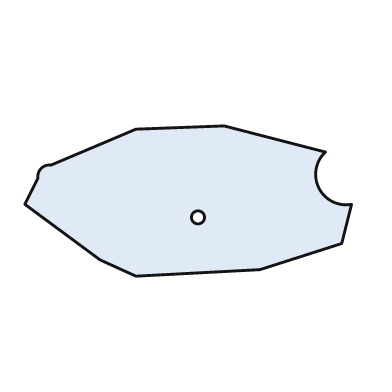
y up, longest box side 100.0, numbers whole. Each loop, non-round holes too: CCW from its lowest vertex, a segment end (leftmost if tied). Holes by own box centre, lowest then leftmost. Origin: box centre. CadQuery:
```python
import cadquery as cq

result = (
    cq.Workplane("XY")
    .moveTo(-16.0, -23.0)
    .lineTo(22.0, -21.0)
    .lineTo(47.0, -13.0)
    .lineTo(50.0, -1.0)
    .threePointArc((40.0, 4.0), (42.0, 15.0))
    .lineTo(11.0, 23.0)
    .lineTo(-16.0, 22.0)
    .lineTo(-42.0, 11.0)
    .threePointArc((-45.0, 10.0), (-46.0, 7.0))
    .lineTo(-50.0, -1.0)
    .lineTo(-27.0, -18.0)
    .close()
    .moveTo(3.0, -5.0)
    .circle(2.0)
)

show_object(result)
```